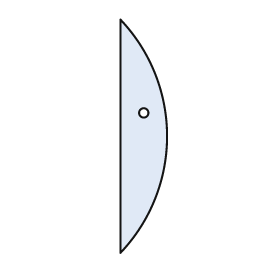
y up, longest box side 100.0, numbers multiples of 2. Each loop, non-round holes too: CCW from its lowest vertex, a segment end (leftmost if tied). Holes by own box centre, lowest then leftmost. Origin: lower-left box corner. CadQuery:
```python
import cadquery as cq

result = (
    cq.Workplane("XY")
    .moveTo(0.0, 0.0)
    .threePointArc((20.0, 50.0), (0.0, 100.0))
    .close()
    .moveTo(10.0, 60.0)
    .circle(2.0)
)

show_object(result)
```